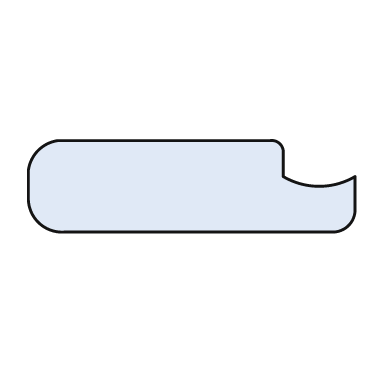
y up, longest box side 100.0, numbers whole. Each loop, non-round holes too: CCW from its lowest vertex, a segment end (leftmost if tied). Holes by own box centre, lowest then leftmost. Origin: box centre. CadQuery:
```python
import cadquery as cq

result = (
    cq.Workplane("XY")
    .moveTo(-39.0, -14.0)
    .lineTo(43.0, -14.0)
    .threePointArc((48.0, -12.0), (50.0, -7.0))
    .lineTo(50.0, 3.0)
    .threePointArc((39.0, 0.0), (28.0, 3.0))
    .lineTo(28.0, 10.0)
    .threePointArc((27.0, 13.0), (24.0, 14.0))
    .lineTo(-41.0, 14.0)
    .threePointArc((-47.0, 11.0), (-50.0, 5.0))
    .lineTo(-50.0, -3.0)
    .threePointArc((-47.0, -11.0), (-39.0, -14.0))
    .close()
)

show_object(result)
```